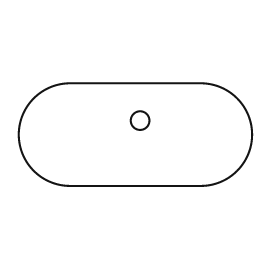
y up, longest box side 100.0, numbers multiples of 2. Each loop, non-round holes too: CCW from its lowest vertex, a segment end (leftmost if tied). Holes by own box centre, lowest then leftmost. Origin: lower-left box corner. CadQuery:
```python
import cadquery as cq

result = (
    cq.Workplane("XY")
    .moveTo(22.0, 0.0)
    .lineTo(78.0, 0.0)
    .threePointArc((100.0, 22.0), (78.0, 44.0))
    .lineTo(22.0, 44.0)
    .threePointArc((0.0, 22.0), (22.0, 0.0))
    .close()
    .moveTo(52.0, 28.0)
    .circle(4.0)
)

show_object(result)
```